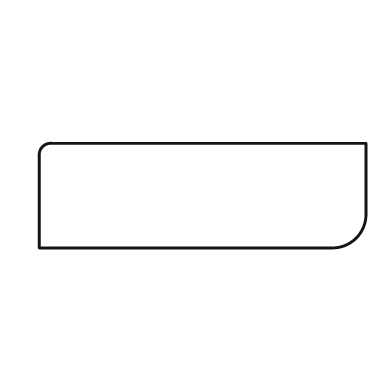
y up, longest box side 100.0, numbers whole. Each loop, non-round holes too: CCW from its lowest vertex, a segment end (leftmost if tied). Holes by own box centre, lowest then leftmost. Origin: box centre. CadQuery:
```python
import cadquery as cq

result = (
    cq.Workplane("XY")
    .moveTo(-50.0, -16.0)
    .lineTo(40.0, -16.0)
    .threePointArc((47.0, -13.0), (50.0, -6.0))
    .lineTo(50.0, 16.0)
    .lineTo(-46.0, 16.0)
    .threePointArc((-49.0, 15.0), (-50.0, 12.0))
    .close()
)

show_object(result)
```